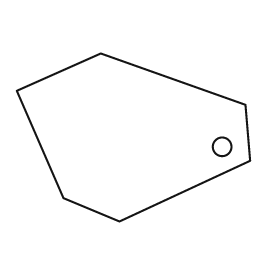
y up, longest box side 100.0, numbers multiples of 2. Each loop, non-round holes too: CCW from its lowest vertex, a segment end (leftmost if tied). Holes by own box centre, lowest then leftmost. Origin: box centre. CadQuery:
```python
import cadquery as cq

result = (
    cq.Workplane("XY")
    .moveTo(-6.0, -36.0)
    .lineTo(50.0, -10.0)
    .lineTo(48.0, 14.0)
    .lineTo(-14.0, 36.0)
    .lineTo(-50.0, 20.0)
    .lineTo(-30.0, -26.0)
    .close()
    .moveTo(38.0, -4.0)
    .circle(4.0)
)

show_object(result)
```